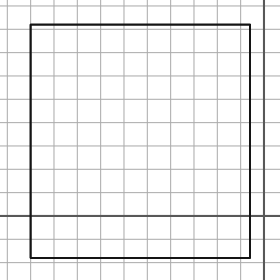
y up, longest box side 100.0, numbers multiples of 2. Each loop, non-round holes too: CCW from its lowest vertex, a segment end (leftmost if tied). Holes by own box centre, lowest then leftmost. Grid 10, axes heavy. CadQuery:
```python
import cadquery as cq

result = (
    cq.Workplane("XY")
    .moveTo(-100.0, -18.0)
    .lineTo(-6.0, -18.0)
    .lineTo(-6.0, 82.0)
    .lineTo(-100.0, 82.0)
    .close()
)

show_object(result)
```